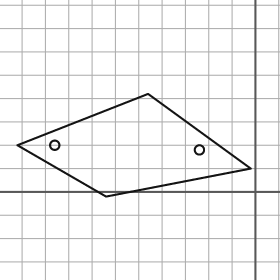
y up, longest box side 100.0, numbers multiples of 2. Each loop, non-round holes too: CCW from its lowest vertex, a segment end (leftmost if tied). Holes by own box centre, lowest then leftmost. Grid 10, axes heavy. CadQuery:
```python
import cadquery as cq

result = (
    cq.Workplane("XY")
    .moveTo(-64.0, -2.0)
    .lineTo(-2.0, 10.0)
    .lineTo(-46.0, 42.0)
    .lineTo(-102.0, 20.0)
    .close()
    .moveTo(-24.0, 18.0)
    .circle(2.0)
    .moveTo(-86.0, 20.0)
    .circle(2.0)
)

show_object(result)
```